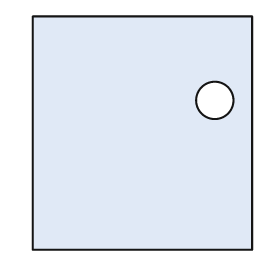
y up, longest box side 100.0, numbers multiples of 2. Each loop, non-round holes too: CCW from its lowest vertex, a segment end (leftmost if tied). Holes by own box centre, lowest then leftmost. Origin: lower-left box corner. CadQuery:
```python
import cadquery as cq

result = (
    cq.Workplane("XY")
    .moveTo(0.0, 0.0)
    .lineTo(94.0, 0.0)
    .lineTo(94.0, 100.0)
    .lineTo(0.0, 100.0)
    .close()
    .moveTo(78.0, 64.0)
    .circle(8.0)
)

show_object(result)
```